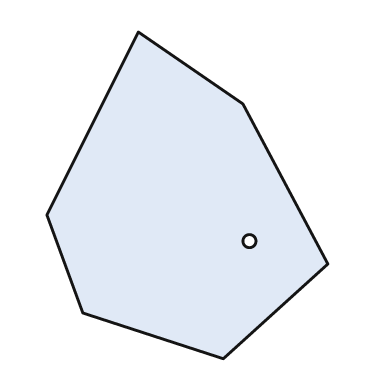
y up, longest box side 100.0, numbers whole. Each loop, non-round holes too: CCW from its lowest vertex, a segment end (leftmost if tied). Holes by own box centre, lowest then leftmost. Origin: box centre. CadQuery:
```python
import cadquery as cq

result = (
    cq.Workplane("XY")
    .moveTo(11.0, -50.0)
    .lineTo(43.0, -21.0)
    .lineTo(17.0, 28.0)
    .lineTo(-15.0, 50.0)
    .lineTo(-43.0, -6.0)
    .lineTo(-32.0, -36.0)
    .close()
    .moveTo(19.0, -14.0)
    .circle(2.0)
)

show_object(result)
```